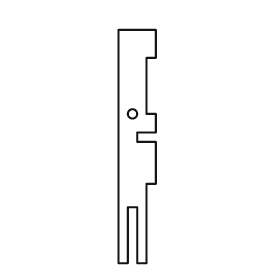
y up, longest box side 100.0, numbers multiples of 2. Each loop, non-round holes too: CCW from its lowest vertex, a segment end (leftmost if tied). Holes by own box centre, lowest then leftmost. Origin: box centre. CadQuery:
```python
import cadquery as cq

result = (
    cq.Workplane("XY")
    .moveTo(-8.0, -50.0)
    .lineTo(-4.0, -50.0)
    .lineTo(-4.0, -26.0)
    .lineTo(0.0, -26.0)
    .lineTo(0.0, -50.0)
    .lineTo(4.0, -50.0)
    .lineTo(4.0, -16.0)
    .lineTo(8.0, -16.0)
    .lineTo(8.0, 2.0)
    .lineTo(0.0, 2.0)
    .lineTo(0.0, 6.0)
    .lineTo(8.0, 6.0)
    .lineTo(8.0, 14.0)
    .lineTo(4.0, 14.0)
    .lineTo(4.0, 38.0)
    .lineTo(8.0, 38.0)
    .lineTo(8.0, 50.0)
    .lineTo(-8.0, 50.0)
    .close()
    .moveTo(-2.0, 14.0)
    .circle(2.0)
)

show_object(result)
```